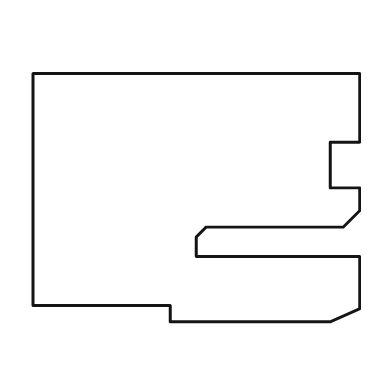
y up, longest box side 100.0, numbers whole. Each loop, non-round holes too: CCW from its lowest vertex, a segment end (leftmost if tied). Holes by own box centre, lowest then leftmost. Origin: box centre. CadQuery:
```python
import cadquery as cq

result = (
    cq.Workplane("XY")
    .moveTo(-8.0, -38.0)
    .lineTo(41.0, -38.0)
    .lineTo(50.0, -34.0)
    .lineTo(50.0, -18.0)
    .lineTo(0.0, -18.0)
    .lineTo(0.0, -12.0)
    .lineTo(3.0, -9.0)
    .lineTo(45.0, -9.0)
    .lineTo(50.0, -4.0)
    .lineTo(50.0, 3.0)
    .lineTo(41.0, 3.0)
    .lineTo(41.0, 17.0)
    .lineTo(50.0, 17.0)
    .lineTo(50.0, 38.0)
    .lineTo(-50.0, 38.0)
    .lineTo(-50.0, -33.0)
    .lineTo(-8.0, -33.0)
    .close()
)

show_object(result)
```